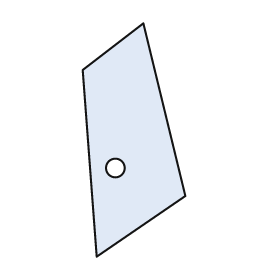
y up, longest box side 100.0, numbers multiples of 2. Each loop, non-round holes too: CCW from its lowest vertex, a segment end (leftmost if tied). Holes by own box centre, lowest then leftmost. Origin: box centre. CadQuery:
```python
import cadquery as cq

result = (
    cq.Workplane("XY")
    .moveTo(-16.0, -50.0)
    .lineTo(22.0, -24.0)
    .lineTo(4.0, 50.0)
    .lineTo(-22.0, 30.0)
    .close()
    .moveTo(-8.0, -12.0)
    .circle(4.0)
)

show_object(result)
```